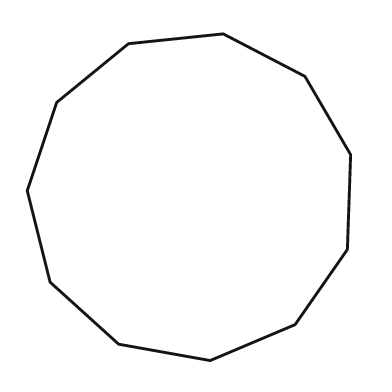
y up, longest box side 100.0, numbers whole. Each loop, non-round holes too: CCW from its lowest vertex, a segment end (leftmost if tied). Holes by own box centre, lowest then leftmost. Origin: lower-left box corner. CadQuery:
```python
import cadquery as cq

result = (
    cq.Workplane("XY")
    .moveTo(56.0, 0.0)
    .lineTo(82.0, 11.0)
    .lineTo(98.0, 34.0)
    .lineTo(99.0, 63.0)
    .lineTo(85.0, 87.0)
    .lineTo(60.0, 100.0)
    .lineTo(31.0, 97.0)
    .lineTo(9.0, 79.0)
    .lineTo(0.0, 52.0)
    .lineTo(7.0, 24.0)
    .lineTo(28.0, 5.0)
    .close()
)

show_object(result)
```